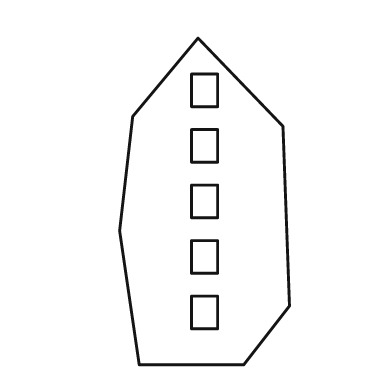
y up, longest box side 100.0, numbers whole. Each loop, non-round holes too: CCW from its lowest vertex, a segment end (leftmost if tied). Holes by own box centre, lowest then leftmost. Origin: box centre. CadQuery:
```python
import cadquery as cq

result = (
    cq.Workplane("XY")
    .moveTo(-20.0, -50.0)
    .lineTo(12.0, -50.0)
    .lineTo(26.0, -32.0)
    .lineTo(24.0, 23.0)
    .lineTo(-2.0, 50.0)
    .lineTo(-22.0, 26.0)
    .lineTo(-26.0, -9.0)
    .close()
    .moveTo(-4.0, -39.0)
    .lineTo(4.0, -39.0)
    .lineTo(4.0, -29.0)
    .lineTo(-4.0, -29.0)
    .close()
    .moveTo(-4.0, -22.0)
    .lineTo(4.0, -22.0)
    .lineTo(4.0, -12.0)
    .lineTo(-4.0, -12.0)
    .close()
    .moveTo(-4.0, -5.0)
    .lineTo(4.0, -5.0)
    .lineTo(4.0, 5.0)
    .lineTo(-4.0, 5.0)
    .close()
    .moveTo(-4.0, 12.0)
    .lineTo(4.0, 12.0)
    .lineTo(4.0, 22.0)
    .lineTo(-4.0, 22.0)
    .close()
    .moveTo(-4.0, 29.0)
    .lineTo(4.0, 29.0)
    .lineTo(4.0, 39.0)
    .lineTo(-4.0, 39.0)
    .close()
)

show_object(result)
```